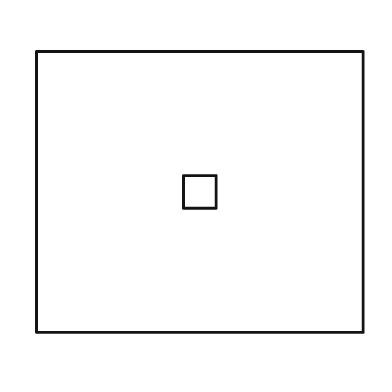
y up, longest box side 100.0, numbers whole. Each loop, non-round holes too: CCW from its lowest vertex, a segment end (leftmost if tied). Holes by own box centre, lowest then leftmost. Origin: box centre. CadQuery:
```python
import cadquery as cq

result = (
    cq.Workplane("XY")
    .moveTo(-50.0, -43.0)
    .lineTo(50.0, -43.0)
    .lineTo(50.0, 43.0)
    .lineTo(-50.0, 43.0)
    .close()
    .moveTo(-5.0, -5.0)
    .lineTo(5.0, -5.0)
    .lineTo(5.0, 5.0)
    .lineTo(-5.0, 5.0)
    .close()
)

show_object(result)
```